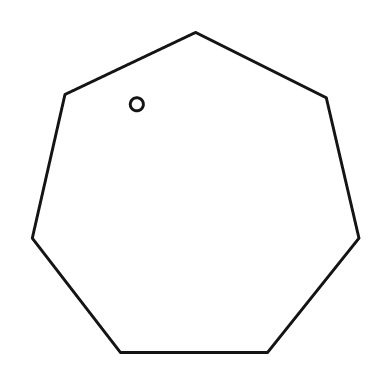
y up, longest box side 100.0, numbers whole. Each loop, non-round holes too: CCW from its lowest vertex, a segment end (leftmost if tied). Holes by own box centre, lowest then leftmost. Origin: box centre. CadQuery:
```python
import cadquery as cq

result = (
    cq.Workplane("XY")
    .moveTo(-23.0, -49.0)
    .lineTo(22.0, -49.0)
    .lineTo(50.0, -14.0)
    .lineTo(40.0, 29.0)
    .lineTo(0.0, 49.0)
    .lineTo(-40.0, 30.0)
    .lineTo(-50.0, -14.0)
    .close()
    .moveTo(-18.0, 27.0)
    .circle(2.0)
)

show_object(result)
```